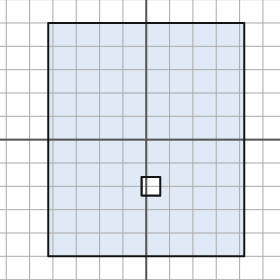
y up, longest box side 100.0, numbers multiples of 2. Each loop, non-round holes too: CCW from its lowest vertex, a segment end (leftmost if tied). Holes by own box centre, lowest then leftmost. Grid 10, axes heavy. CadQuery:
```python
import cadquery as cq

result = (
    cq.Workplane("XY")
    .moveTo(-42.0, -50.0)
    .lineTo(42.0, -50.0)
    .lineTo(42.0, 50.0)
    .lineTo(-42.0, 50.0)
    .close()
    .moveTo(-2.0, -24.0)
    .lineTo(6.0, -24.0)
    .lineTo(6.0, -16.0)
    .lineTo(-2.0, -16.0)
    .close()
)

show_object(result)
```